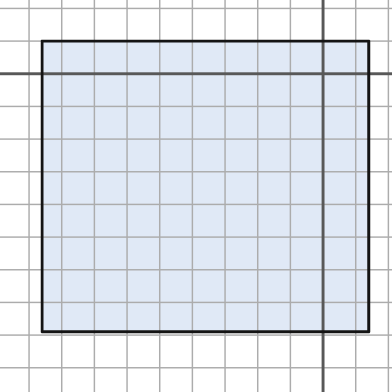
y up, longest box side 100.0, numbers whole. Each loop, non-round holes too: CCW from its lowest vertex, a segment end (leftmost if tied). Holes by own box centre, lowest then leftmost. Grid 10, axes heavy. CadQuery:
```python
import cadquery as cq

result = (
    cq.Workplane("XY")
    .moveTo(-86.0, -79.0)
    .lineTo(14.0, -79.0)
    .lineTo(14.0, 10.0)
    .lineTo(-86.0, 10.0)
    .close()
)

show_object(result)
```